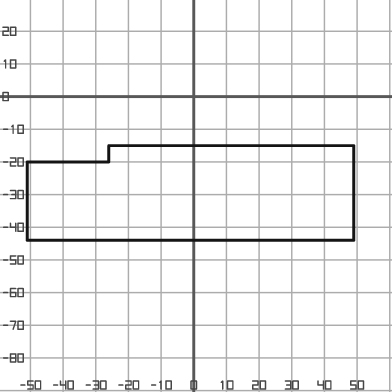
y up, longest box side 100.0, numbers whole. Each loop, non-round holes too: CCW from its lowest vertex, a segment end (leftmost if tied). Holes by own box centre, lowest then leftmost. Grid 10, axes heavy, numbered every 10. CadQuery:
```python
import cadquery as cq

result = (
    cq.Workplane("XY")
    .moveTo(-51.0, -44.0)
    .lineTo(49.0, -44.0)
    .lineTo(49.0, -15.0)
    .lineTo(-26.0, -15.0)
    .lineTo(-26.0, -20.0)
    .lineTo(-51.0, -20.0)
    .close()
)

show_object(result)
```